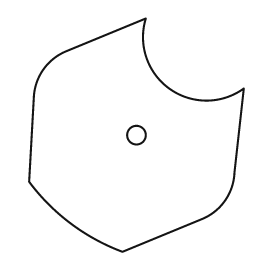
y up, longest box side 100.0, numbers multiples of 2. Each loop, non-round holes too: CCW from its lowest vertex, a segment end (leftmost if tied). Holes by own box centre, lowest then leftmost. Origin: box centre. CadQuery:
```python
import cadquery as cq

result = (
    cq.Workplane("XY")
    .moveTo(-6.0, -50.0)
    .lineTo(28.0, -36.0)
    .threePointArc((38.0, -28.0), (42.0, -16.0))
    .lineTo(46.0, 20.0)
    .threePointArc((14.0, 20.0), (4.0, 50.0))
    .lineTo(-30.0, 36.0)
    .threePointArc((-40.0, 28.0), (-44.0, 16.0))
    .lineTo(-46.0, -20.0)
    .threePointArc((-28.0, -38.0), (-6.0, -50.0))
    .close()
    .moveTo(0.0, 0.0)
    .circle(4.0)
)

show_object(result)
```